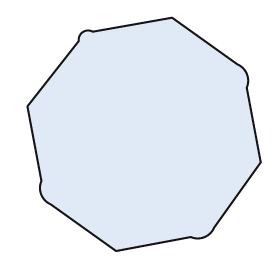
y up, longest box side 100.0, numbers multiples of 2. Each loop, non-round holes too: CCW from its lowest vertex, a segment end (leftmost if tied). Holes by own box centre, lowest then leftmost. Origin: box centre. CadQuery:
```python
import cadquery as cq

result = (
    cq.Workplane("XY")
    .moveTo(-12.0, -50.0)
    .lineTo(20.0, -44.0)
    .threePointArc((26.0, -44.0), (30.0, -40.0))
    .lineTo(50.0, -12.0)
    .lineTo(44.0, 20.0)
    .threePointArc((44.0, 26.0), (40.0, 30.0))
    .lineTo(12.0, 50.0)
    .lineTo(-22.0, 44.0)
    .threePointArc((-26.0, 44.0), (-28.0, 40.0))
    .lineTo(-50.0, 12.0)
    .lineTo(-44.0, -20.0)
    .threePointArc((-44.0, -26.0), (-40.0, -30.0))
    .close()
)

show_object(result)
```